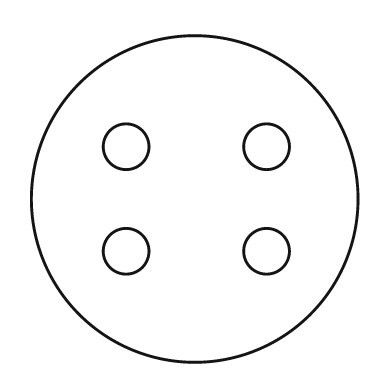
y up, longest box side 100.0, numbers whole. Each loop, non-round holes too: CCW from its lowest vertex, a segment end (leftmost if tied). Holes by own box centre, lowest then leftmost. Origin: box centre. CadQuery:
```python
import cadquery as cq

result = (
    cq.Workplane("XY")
    .moveTo(0.0, 0.0)
    .circle(50.0)
    .moveTo(-21.0, -16.0)
    .circle(7.0)
    .moveTo(22.0, -16.0)
    .circle(7.0)
    .moveTo(-21.0, 16.0)
    .circle(7.0)
    .moveTo(22.0, 16.0)
    .circle(7.0)
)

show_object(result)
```